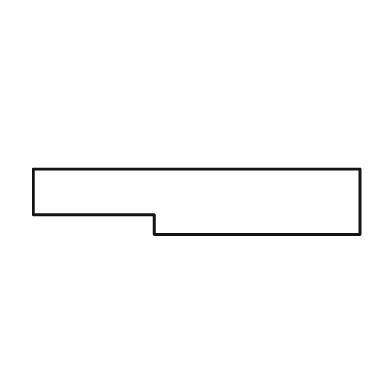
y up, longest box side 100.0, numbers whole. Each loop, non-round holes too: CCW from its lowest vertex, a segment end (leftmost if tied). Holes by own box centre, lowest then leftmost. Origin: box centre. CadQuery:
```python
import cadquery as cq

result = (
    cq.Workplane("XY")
    .moveTo(-13.0, -10.0)
    .lineTo(50.0, -10.0)
    .lineTo(50.0, 10.0)
    .lineTo(-50.0, 10.0)
    .lineTo(-50.0, -4.0)
    .lineTo(-13.0, -4.0)
    .close()
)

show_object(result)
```